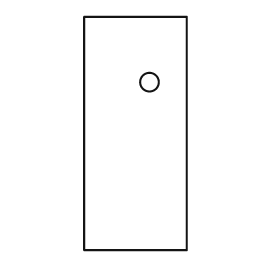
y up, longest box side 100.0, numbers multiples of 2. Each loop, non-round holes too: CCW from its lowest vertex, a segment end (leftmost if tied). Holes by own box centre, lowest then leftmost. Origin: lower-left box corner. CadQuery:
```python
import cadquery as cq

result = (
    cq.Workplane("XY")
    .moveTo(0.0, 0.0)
    .lineTo(44.0, 0.0)
    .lineTo(44.0, 100.0)
    .lineTo(0.0, 100.0)
    .close()
    .moveTo(28.0, 72.0)
    .circle(4.0)
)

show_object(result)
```